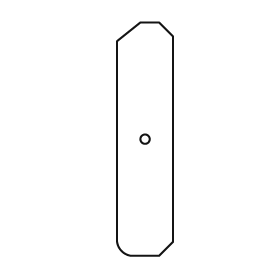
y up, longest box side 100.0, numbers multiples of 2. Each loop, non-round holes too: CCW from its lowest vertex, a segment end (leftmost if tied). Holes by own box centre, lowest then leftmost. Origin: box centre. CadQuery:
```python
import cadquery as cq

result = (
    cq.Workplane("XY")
    .moveTo(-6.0, -50.0)
    .lineTo(6.0, -50.0)
    .lineTo(12.0, -44.0)
    .lineTo(12.0, 44.0)
    .lineTo(6.0, 50.0)
    .lineTo(-2.0, 50.0)
    .lineTo(-12.0, 42.0)
    .lineTo(-12.0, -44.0)
    .threePointArc((-10.0, -48.0), (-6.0, -50.0))
    .close()
    .moveTo(0.0, 0.0)
    .circle(2.0)
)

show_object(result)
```